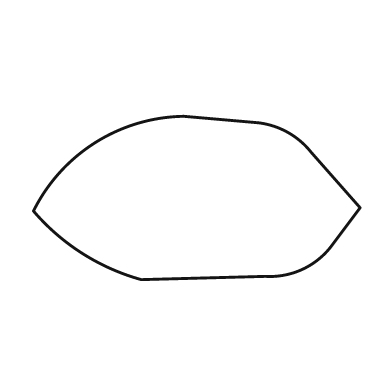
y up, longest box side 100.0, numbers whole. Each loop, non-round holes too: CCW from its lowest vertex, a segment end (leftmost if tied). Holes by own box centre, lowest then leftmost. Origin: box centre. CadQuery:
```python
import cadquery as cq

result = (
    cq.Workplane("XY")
    .moveTo(-17.0, -25.0)
    .lineTo(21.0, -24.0)
    .threePointArc((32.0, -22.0), (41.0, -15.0))
    .lineTo(50.0, -3.0)
    .lineTo(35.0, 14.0)
    .threePointArc((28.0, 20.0), (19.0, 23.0))
    .lineTo(-4.0, 25.0)
    .threePointArc((-31.0, 17.0), (-50.0, -4.0))
    .threePointArc((-35.0, -17.0), (-17.0, -25.0))
    .close()
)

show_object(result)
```